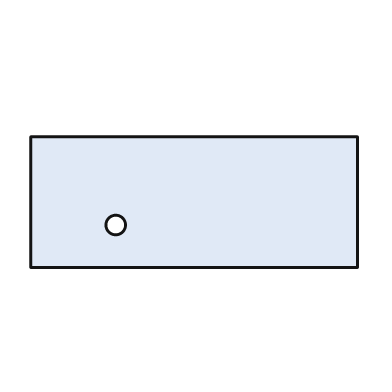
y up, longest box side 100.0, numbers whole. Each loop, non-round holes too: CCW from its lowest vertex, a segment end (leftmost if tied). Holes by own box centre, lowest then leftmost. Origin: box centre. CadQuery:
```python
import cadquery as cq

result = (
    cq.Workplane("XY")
    .moveTo(-50.0, -20.0)
    .lineTo(50.0, -20.0)
    .lineTo(50.0, 20.0)
    .lineTo(-50.0, 20.0)
    .close()
    .moveTo(-24.0, -7.0)
    .circle(3.0)
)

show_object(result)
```